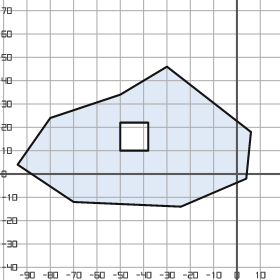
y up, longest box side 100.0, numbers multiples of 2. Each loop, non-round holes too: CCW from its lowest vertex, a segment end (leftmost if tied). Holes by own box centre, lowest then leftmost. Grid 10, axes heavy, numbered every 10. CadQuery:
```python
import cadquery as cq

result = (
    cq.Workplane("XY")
    .moveTo(-24.0, -14.0)
    .lineTo(4.0, -2.0)
    .lineTo(6.0, 18.0)
    .lineTo(-30.0, 46.0)
    .lineTo(-50.0, 34.0)
    .lineTo(-80.0, 24.0)
    .lineTo(-94.0, 4.0)
    .lineTo(-70.0, -12.0)
    .close()
    .moveTo(-50.0, 10.0)
    .lineTo(-38.0, 10.0)
    .lineTo(-38.0, 22.0)
    .lineTo(-50.0, 22.0)
    .close()
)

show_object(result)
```